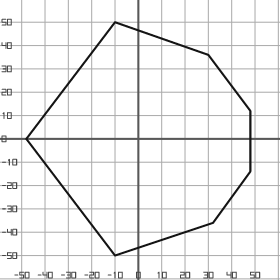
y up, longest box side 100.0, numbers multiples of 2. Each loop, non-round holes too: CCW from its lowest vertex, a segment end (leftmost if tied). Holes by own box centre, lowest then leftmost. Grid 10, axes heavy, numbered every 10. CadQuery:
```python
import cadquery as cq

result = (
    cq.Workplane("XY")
    .moveTo(-10.0, -50.0)
    .lineTo(32.0, -36.0)
    .lineTo(48.0, -14.0)
    .lineTo(48.0, 12.0)
    .lineTo(30.0, 36.0)
    .lineTo(-10.0, 50.0)
    .lineTo(-48.0, 0.0)
    .close()
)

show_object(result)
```